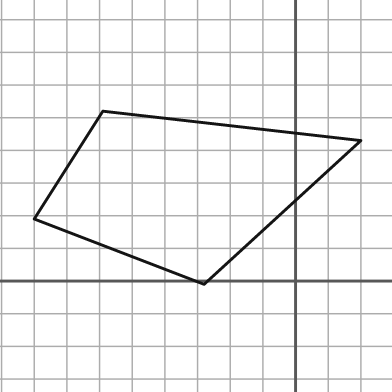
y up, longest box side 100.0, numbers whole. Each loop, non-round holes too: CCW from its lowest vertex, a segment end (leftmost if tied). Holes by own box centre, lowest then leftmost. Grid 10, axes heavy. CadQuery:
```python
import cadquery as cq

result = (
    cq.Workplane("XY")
    .moveTo(-28.0, -1.0)
    .lineTo(20.0, 43.0)
    .lineTo(-59.0, 52.0)
    .lineTo(-80.0, 19.0)
    .close()
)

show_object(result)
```